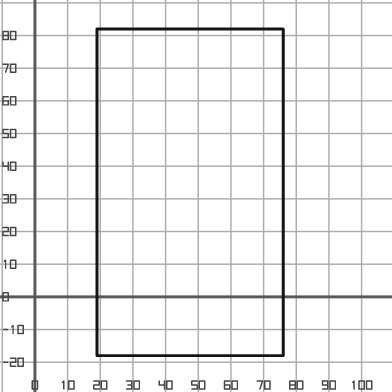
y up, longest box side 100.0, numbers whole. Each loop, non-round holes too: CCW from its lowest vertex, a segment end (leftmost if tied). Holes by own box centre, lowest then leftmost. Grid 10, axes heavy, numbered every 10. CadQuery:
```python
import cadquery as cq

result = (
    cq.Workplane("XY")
    .moveTo(19.0, -18.0)
    .lineTo(76.0, -18.0)
    .lineTo(76.0, 82.0)
    .lineTo(19.0, 82.0)
    .close()
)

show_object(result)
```